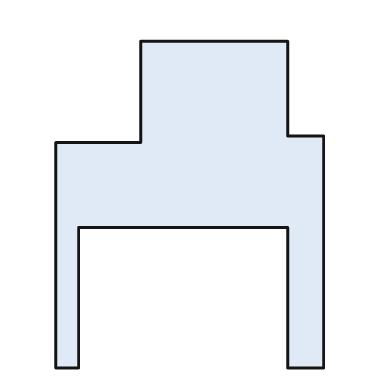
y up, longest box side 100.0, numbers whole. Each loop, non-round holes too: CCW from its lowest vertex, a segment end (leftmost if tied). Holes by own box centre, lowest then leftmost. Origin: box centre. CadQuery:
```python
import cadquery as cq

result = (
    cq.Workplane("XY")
    .moveTo(-41.0, -50.0)
    .lineTo(-34.0, -50.0)
    .lineTo(-34.0, -7.0)
    .lineTo(30.0, -7.0)
    .lineTo(30.0, -50.0)
    .lineTo(41.0, -50.0)
    .lineTo(41.0, 21.0)
    .lineTo(30.0, 21.0)
    .lineTo(30.0, 50.0)
    .lineTo(-15.0, 50.0)
    .lineTo(-15.0, 19.0)
    .lineTo(-41.0, 19.0)
    .close()
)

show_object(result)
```